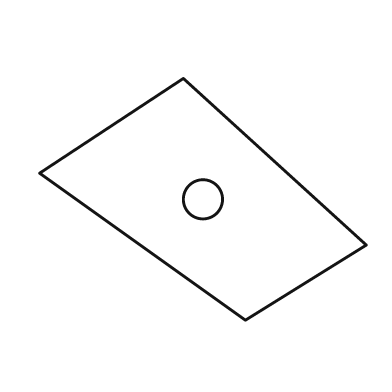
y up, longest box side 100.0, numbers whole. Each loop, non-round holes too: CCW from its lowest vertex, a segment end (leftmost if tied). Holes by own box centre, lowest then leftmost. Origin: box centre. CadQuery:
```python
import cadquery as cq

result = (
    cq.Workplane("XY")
    .moveTo(13.0, -37.0)
    .lineTo(50.0, -14.0)
    .lineTo(-6.0, 37.0)
    .lineTo(-50.0, 8.0)
    .close()
    .moveTo(0.0, 0.0)
    .circle(6.0)
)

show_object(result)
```